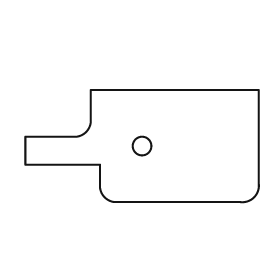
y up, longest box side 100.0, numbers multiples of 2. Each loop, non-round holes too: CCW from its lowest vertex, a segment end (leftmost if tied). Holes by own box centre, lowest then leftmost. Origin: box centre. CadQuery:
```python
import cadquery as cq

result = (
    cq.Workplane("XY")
    .moveTo(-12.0, -24.0)
    .lineTo(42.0, -24.0)
    .threePointArc((48.0, -22.0), (50.0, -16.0))
    .lineTo(50.0, 24.0)
    .lineTo(-22.0, 24.0)
    .lineTo(-22.0, 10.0)
    .threePointArc((-24.0, 6.0), (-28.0, 4.0))
    .lineTo(-50.0, 4.0)
    .lineTo(-50.0, -8.0)
    .lineTo(-18.0, -8.0)
    .lineTo(-18.0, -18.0)
    .threePointArc((-16.0, -22.0), (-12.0, -24.0))
    .close()
    .moveTo(0.0, 0.0)
    .circle(4.0)
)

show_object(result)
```